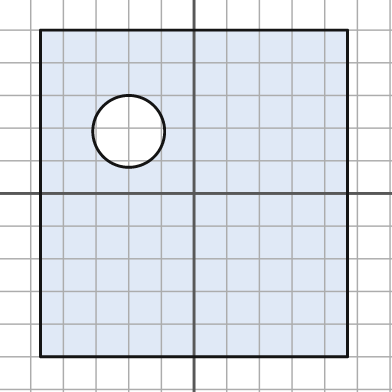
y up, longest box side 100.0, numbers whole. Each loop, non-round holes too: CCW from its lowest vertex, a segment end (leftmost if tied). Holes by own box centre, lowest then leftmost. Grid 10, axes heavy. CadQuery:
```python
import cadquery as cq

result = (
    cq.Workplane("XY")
    .moveTo(-47.0, -50.0)
    .lineTo(47.0, -50.0)
    .lineTo(47.0, 50.0)
    .lineTo(-47.0, 50.0)
    .close()
    .moveTo(-20.0, 19.0)
    .circle(11.0)
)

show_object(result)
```